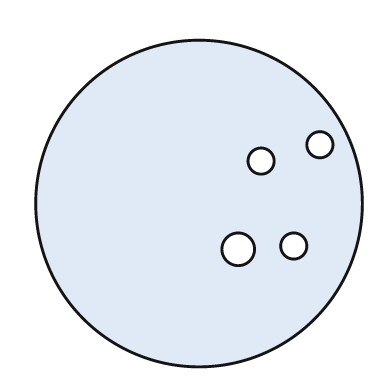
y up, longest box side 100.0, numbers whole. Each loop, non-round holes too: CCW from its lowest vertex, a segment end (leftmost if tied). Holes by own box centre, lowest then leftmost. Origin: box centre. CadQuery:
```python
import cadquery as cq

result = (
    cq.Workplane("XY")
    .moveTo(0.0, 0.0)
    .circle(50.0)
    .moveTo(12.0, -14.0)
    .circle(5.0)
    .moveTo(29.0, -13.0)
    .circle(4.0)
    .moveTo(19.0, 13.0)
    .circle(4.0)
    .moveTo(37.0, 18.0)
    .circle(4.0)
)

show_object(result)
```